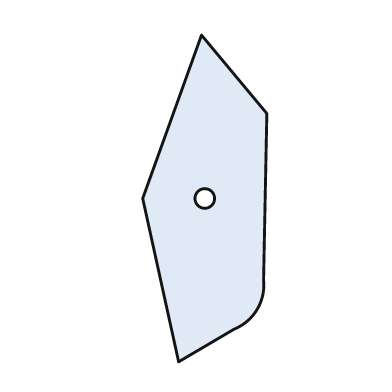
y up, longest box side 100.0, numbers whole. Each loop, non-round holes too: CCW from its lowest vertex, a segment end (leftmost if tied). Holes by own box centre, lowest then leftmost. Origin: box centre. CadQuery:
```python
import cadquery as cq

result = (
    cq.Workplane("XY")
    .moveTo(-8.0, -50.0)
    .lineTo(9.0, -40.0)
    .threePointArc((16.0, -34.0), (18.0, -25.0))
    .lineTo(19.0, 26.0)
    .lineTo(-1.0, 50.0)
    .lineTo(-19.0, 0.0)
    .close()
    .moveTo(0.0, 0.0)
    .circle(3.0)
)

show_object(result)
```